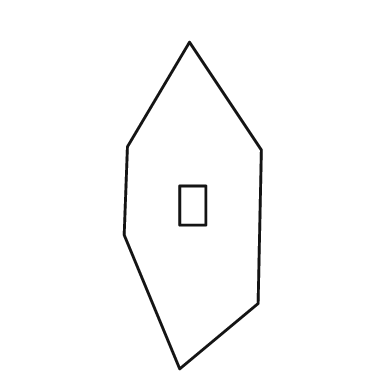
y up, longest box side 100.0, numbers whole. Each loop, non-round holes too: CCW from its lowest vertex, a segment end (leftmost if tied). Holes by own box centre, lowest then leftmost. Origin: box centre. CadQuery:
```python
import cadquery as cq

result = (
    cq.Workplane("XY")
    .moveTo(-4.0, -50.0)
    .lineTo(20.0, -30.0)
    .lineTo(21.0, 17.0)
    .lineTo(-1.0, 50.0)
    .lineTo(-20.0, 18.0)
    .lineTo(-21.0, -9.0)
    .close()
    .moveTo(-4.0, -6.0)
    .lineTo(4.0, -6.0)
    .lineTo(4.0, 6.0)
    .lineTo(-4.0, 6.0)
    .close()
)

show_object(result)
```